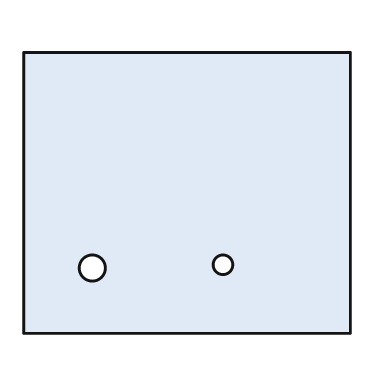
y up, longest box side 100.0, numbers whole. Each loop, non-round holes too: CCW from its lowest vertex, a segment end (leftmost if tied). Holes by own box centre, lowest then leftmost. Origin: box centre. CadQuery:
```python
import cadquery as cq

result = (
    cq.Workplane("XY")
    .moveTo(-50.0, -43.0)
    .lineTo(50.0, -43.0)
    .lineTo(50.0, 43.0)
    .lineTo(-50.0, 43.0)
    .close()
    .moveTo(-29.0, -23.0)
    .circle(4.0)
    .moveTo(11.0, -22.0)
    .circle(3.0)
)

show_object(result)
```